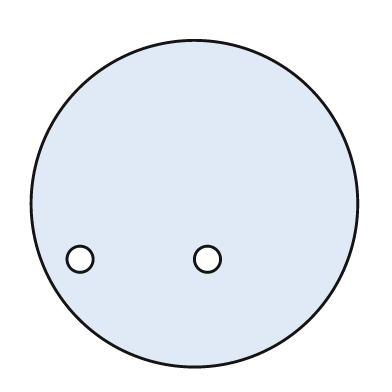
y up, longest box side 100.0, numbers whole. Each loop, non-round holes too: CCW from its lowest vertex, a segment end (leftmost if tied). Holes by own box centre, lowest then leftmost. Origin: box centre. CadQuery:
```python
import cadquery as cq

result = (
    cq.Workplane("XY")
    .moveTo(0.0, 0.0)
    .circle(50.0)
    .moveTo(-35.0, -17.0)
    .circle(4.0)
    .moveTo(4.0, -17.0)
    .circle(4.0)
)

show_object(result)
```